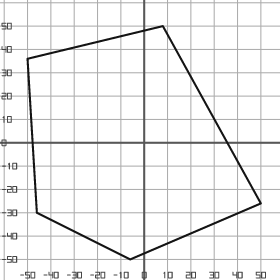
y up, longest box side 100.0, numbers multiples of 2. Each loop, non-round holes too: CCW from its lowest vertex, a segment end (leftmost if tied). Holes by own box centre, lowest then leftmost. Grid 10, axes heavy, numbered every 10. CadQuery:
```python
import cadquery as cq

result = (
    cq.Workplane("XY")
    .moveTo(-6.0, -50.0)
    .lineTo(50.0, -26.0)
    .lineTo(8.0, 50.0)
    .lineTo(-50.0, 36.0)
    .lineTo(-46.0, -30.0)
    .close()
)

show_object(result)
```